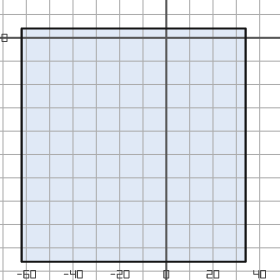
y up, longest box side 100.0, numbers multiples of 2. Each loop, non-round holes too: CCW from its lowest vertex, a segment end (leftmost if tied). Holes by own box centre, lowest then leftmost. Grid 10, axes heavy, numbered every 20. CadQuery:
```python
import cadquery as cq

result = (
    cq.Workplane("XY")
    .moveTo(-62.0, -96.0)
    .lineTo(34.0, -96.0)
    .lineTo(34.0, 4.0)
    .lineTo(-62.0, 4.0)
    .close()
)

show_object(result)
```